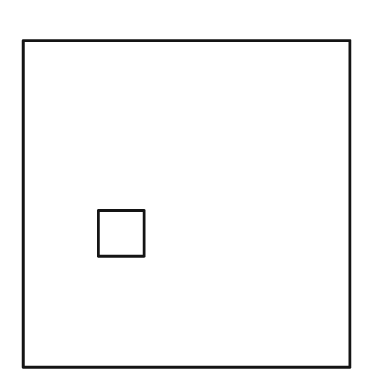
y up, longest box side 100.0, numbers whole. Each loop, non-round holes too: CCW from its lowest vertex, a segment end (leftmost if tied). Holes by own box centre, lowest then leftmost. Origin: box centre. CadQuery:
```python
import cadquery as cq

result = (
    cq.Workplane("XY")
    .moveTo(-50.0, -50.0)
    .lineTo(50.0, -50.0)
    .lineTo(50.0, 50.0)
    .lineTo(-50.0, 50.0)
    .close()
    .moveTo(-27.0, -16.0)
    .lineTo(-13.0, -16.0)
    .lineTo(-13.0, -2.0)
    .lineTo(-27.0, -2.0)
    .close()
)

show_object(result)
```